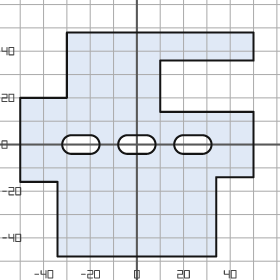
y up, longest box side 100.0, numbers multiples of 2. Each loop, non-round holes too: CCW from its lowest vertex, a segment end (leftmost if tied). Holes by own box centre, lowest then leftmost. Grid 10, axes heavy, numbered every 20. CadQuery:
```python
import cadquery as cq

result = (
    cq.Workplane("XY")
    .moveTo(-34.0, -48.0)
    .lineTo(34.0, -48.0)
    .lineTo(34.0, -14.0)
    .lineTo(50.0, -14.0)
    .lineTo(50.0, 14.0)
    .lineTo(10.0, 14.0)
    .lineTo(10.0, 36.0)
    .lineTo(50.0, 36.0)
    .lineTo(50.0, 48.0)
    .lineTo(-30.0, 48.0)
    .lineTo(-30.0, 20.0)
    .lineTo(-50.0, 20.0)
    .lineTo(-50.0, -16.0)
    .lineTo(-34.0, -16.0)
    .close()
    .moveTo(-28.0, -4.0)
    .lineTo(-20.0, -4.0)
    .threePointArc((-16.0, 0.0), (-20.0, 4.0))
    .lineTo(-28.0, 4.0)
    .threePointArc((-32.0, 0.0), (-28.0, -4.0))
    .close()
    .moveTo(-4.0, -4.0)
    .lineTo(4.0, -4.0)
    .threePointArc((8.0, 0.0), (4.0, 4.0))
    .lineTo(-4.0, 4.0)
    .threePointArc((-8.0, 0.0), (-4.0, -4.0))
    .close()
    .moveTo(20.0, -4.0)
    .lineTo(28.0, -4.0)
    .threePointArc((32.0, 0.0), (28.0, 4.0))
    .lineTo(20.0, 4.0)
    .threePointArc((16.0, 0.0), (20.0, -4.0))
    .close()
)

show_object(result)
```